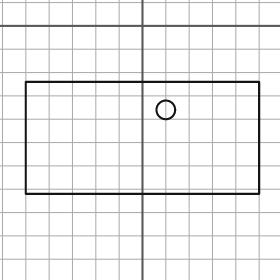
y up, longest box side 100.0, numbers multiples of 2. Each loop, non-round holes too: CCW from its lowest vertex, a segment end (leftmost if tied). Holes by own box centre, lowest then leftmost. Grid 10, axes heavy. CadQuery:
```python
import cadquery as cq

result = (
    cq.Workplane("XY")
    .moveTo(-50.0, -72.0)
    .lineTo(50.0, -72.0)
    .lineTo(50.0, -24.0)
    .lineTo(-50.0, -24.0)
    .close()
    .moveTo(10.0, -36.0)
    .circle(4.0)
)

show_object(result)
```